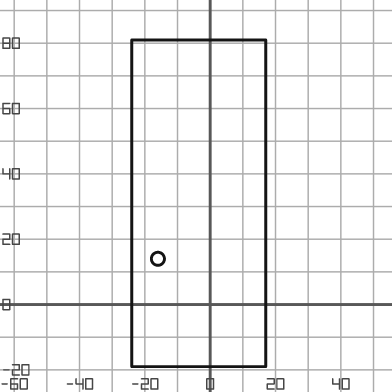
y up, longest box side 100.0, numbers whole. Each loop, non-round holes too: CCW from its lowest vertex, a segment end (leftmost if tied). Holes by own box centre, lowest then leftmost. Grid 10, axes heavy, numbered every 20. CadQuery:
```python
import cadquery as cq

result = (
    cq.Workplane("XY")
    .moveTo(-24.0, -19.0)
    .lineTo(17.0, -19.0)
    .lineTo(17.0, 81.0)
    .lineTo(-24.0, 81.0)
    .close()
    .moveTo(-16.0, 14.0)
    .circle(2.0)
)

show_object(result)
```